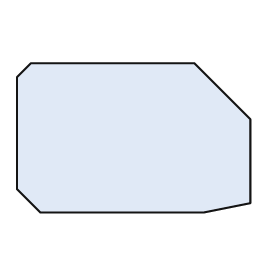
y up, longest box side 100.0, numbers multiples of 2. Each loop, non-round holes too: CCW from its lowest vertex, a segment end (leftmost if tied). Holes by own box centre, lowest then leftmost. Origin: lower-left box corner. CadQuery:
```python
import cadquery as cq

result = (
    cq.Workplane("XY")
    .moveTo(10.0, 0.0)
    .lineTo(80.0, 0.0)
    .lineTo(100.0, 4.0)
    .lineTo(100.0, 40.0)
    .lineTo(76.0, 64.0)
    .lineTo(6.0, 64.0)
    .lineTo(0.0, 58.0)
    .lineTo(0.0, 10.0)
    .close()
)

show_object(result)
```